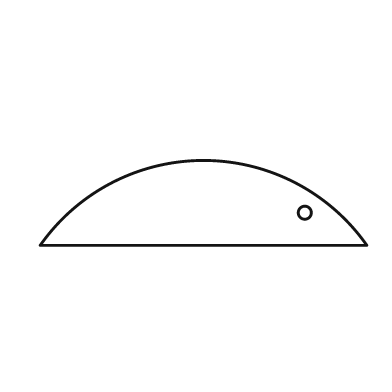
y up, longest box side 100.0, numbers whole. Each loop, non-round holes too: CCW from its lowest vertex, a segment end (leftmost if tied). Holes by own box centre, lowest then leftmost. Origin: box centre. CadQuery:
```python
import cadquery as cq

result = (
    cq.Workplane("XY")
    .moveTo(-50.0, -13.0)
    .lineTo(50.0, -13.0)
    .threePointArc((0.0, 13.0), (-50.0, -13.0))
    .close()
    .moveTo(31.0, -3.0)
    .circle(2.0)
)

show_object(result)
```